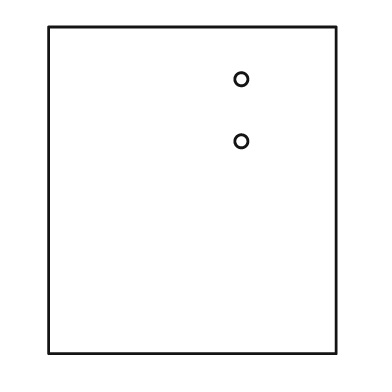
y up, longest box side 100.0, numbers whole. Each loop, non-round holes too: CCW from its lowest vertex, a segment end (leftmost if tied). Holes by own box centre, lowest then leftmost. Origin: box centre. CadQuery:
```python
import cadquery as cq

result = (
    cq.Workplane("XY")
    .moveTo(-44.0, -50.0)
    .lineTo(44.0, -50.0)
    .lineTo(44.0, 50.0)
    .lineTo(-44.0, 50.0)
    .close()
    .moveTo(15.0, 15.0)
    .circle(2.0)
    .moveTo(15.0, 34.0)
    .circle(2.0)
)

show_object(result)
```